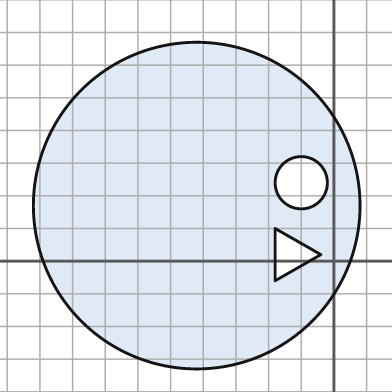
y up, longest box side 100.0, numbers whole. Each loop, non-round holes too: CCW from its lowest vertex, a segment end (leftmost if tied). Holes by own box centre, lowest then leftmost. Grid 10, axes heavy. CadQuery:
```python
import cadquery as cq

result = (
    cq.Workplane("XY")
    .moveTo(-42.0, 17.0)
    .circle(50.0)
    .moveTo(-18.0, -6.0)
    .lineTo(-4.0, 2.0)
    .lineTo(-18.0, 10.0)
    .close()
    .moveTo(-10.0, 24.0)
    .circle(8.0)
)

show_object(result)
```